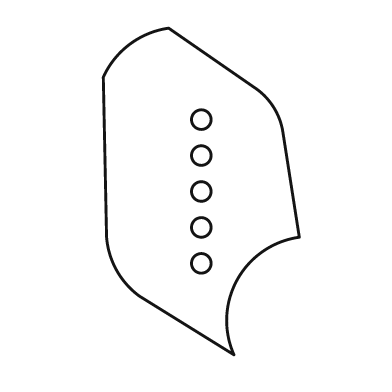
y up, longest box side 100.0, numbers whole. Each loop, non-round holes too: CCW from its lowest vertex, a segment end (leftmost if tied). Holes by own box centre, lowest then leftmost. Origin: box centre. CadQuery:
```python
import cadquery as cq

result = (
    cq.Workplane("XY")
    .moveTo(10.0, -50.0)
    .threePointArc((11.0, -27.0), (30.0, -14.0))
    .lineTo(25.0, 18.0)
    .threePointArc((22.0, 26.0), (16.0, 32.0))
    .lineTo(-10.0, 50.0)
    .threePointArc((-22.0, 45.0), (-30.0, 35.0))
    .lineTo(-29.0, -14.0)
    .threePointArc((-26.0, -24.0), (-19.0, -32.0))
    .close()
    .moveTo(0.0, -22.0)
    .circle(3.0)
    .moveTo(0.0, -11.0)
    .circle(3.0)
    .moveTo(0.0, 0.0)
    .circle(3.0)
    .moveTo(0.0, 11.0)
    .circle(3.0)
    .moveTo(0.0, 22.0)
    .circle(3.0)
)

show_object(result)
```